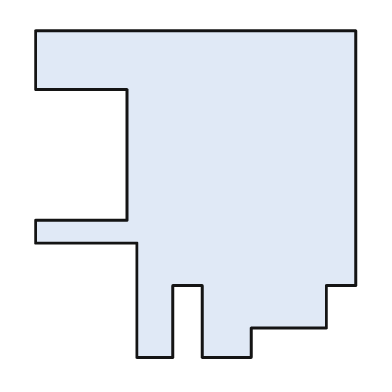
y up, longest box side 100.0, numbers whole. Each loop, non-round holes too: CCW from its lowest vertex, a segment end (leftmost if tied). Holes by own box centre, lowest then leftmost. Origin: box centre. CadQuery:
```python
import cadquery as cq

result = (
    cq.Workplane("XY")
    .moveTo(-18.0, -50.0)
    .lineTo(-7.0, -50.0)
    .lineTo(-7.0, -28.0)
    .lineTo(2.0, -28.0)
    .lineTo(2.0, -50.0)
    .lineTo(17.0, -50.0)
    .lineTo(17.0, -41.0)
    .lineTo(40.0, -41.0)
    .lineTo(40.0, -28.0)
    .lineTo(49.0, -28.0)
    .lineTo(49.0, 50.0)
    .lineTo(-49.0, 50.0)
    .lineTo(-49.0, 32.0)
    .lineTo(-21.0, 32.0)
    .lineTo(-21.0, -8.0)
    .lineTo(-49.0, -8.0)
    .lineTo(-49.0, -15.0)
    .lineTo(-18.0, -15.0)
    .close()
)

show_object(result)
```